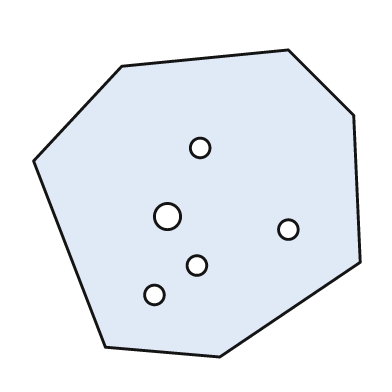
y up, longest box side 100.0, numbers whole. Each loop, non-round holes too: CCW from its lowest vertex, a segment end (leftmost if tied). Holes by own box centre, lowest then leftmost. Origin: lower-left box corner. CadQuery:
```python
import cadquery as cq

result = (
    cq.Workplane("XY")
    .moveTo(57.0, 0.0)
    .lineTo(100.0, 29.0)
    .lineTo(98.0, 74.0)
    .lineTo(78.0, 94.0)
    .lineTo(27.0, 89.0)
    .lineTo(0.0, 60.0)
    .lineTo(22.0, 3.0)
    .close()
    .moveTo(37.0, 19.0)
    .circle(3.0)
    .moveTo(50.0, 28.0)
    .circle(3.0)
    .moveTo(78.0, 39.0)
    .circle(3.0)
    .moveTo(41.0, 43.0)
    .circle(4.0)
    .moveTo(51.0, 64.0)
    .circle(3.0)
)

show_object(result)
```